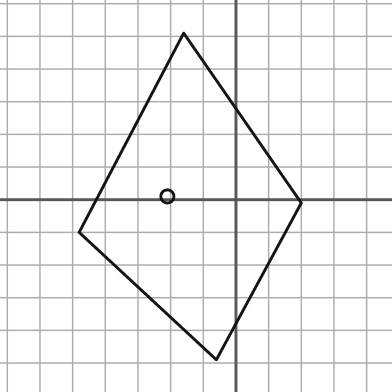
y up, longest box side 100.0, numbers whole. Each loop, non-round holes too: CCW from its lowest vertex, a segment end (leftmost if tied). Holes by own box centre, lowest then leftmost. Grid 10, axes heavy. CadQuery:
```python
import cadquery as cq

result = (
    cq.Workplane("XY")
    .moveTo(-6.0, -49.0)
    .lineTo(20.0, -1.0)
    .lineTo(-16.0, 51.0)
    .lineTo(-48.0, -10.0)
    .close()
    .moveTo(-21.0, 1.0)
    .circle(2.0)
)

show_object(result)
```